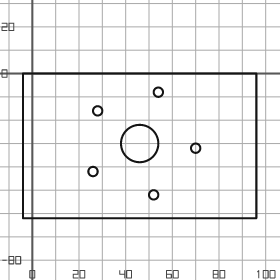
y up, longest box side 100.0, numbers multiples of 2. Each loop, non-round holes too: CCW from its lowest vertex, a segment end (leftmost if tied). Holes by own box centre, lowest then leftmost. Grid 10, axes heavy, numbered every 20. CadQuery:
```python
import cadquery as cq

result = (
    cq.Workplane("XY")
    .moveTo(-4.0, -62.0)
    .lineTo(96.0, -62.0)
    .lineTo(96.0, 0.0)
    .lineTo(-4.0, 0.0)
    .close()
    .moveTo(52.0, -52.0)
    .circle(2.0)
    .moveTo(26.0, -42.0)
    .circle(2.0)
    .moveTo(70.0, -32.0)
    .circle(2.0)
    .moveTo(46.0, -30.0)
    .circle(8.0)
    .moveTo(28.0, -16.0)
    .circle(2.0)
    .moveTo(54.0, -8.0)
    .circle(2.0)
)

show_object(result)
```